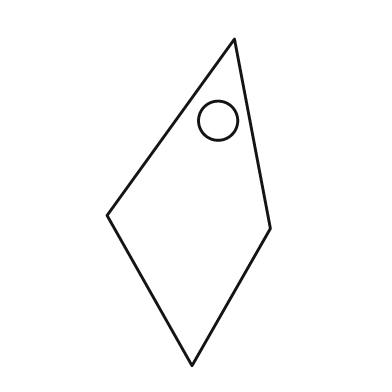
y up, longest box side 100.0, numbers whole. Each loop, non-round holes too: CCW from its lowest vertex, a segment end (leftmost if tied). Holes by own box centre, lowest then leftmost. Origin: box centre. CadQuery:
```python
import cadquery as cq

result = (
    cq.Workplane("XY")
    .moveTo(1.0, -50.0)
    .lineTo(25.0, -8.0)
    .lineTo(14.0, 50.0)
    .lineTo(-25.0, -4.0)
    .close()
    .moveTo(9.0, 25.0)
    .circle(6.0)
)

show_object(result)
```